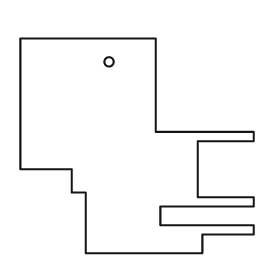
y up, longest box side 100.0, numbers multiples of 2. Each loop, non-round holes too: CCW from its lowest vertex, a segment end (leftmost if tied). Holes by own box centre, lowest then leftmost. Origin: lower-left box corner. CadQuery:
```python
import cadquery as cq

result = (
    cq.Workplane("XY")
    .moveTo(28.0, 0.0)
    .lineTo(78.0, 0.0)
    .lineTo(78.0, 8.0)
    .lineTo(100.0, 8.0)
    .lineTo(100.0, 12.0)
    .lineTo(60.0, 12.0)
    .lineTo(60.0, 20.0)
    .lineTo(100.0, 20.0)
    .lineTo(100.0, 24.0)
    .lineTo(76.0, 24.0)
    .lineTo(76.0, 48.0)
    .lineTo(100.0, 48.0)
    .lineTo(100.0, 52.0)
    .lineTo(58.0, 52.0)
    .lineTo(58.0, 92.0)
    .lineTo(0.0, 92.0)
    .lineTo(0.0, 36.0)
    .lineTo(22.0, 36.0)
    .lineTo(22.0, 26.0)
    .lineTo(28.0, 26.0)
    .close()
    .moveTo(38.0, 82.0)
    .circle(2.0)
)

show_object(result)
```